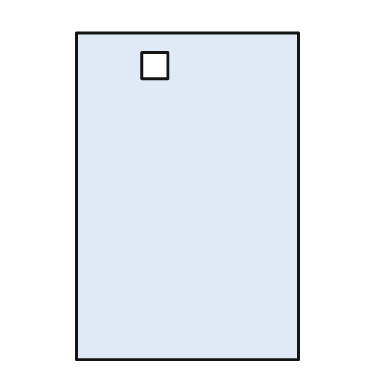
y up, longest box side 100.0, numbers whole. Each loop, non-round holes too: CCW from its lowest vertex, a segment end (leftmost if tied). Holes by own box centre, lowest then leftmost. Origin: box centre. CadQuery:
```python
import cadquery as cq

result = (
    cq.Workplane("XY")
    .moveTo(-34.0, -50.0)
    .lineTo(34.0, -50.0)
    .lineTo(34.0, 50.0)
    .lineTo(-34.0, 50.0)
    .close()
    .moveTo(-14.0, 36.0)
    .lineTo(-6.0, 36.0)
    .lineTo(-6.0, 44.0)
    .lineTo(-14.0, 44.0)
    .close()
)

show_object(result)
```